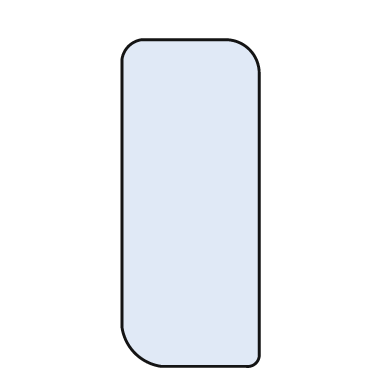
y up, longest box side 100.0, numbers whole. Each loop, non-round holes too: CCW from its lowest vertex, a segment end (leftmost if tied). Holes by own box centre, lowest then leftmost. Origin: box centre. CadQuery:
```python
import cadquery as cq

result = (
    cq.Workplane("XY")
    .moveTo(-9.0, -50.0)
    .lineTo(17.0, -50.0)
    .threePointArc((20.0, -49.0), (21.0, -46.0))
    .lineTo(21.0, 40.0)
    .threePointArc((18.0, 47.0), (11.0, 50.0))
    .lineTo(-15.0, 50.0)
    .threePointArc((-19.0, 48.0), (-21.0, 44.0))
    .lineTo(-21.0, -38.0)
    .threePointArc((-17.0, -46.0), (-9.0, -50.0))
    .close()
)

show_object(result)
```